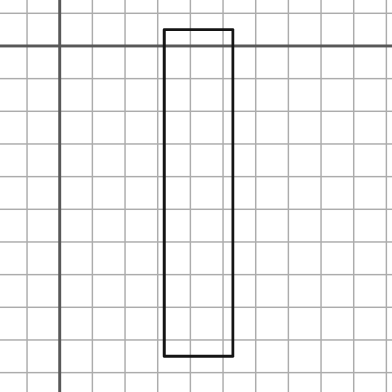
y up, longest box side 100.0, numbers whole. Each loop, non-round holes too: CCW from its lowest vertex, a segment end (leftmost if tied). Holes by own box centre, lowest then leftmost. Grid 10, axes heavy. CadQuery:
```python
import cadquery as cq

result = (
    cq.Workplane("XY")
    .moveTo(32.0, -95.0)
    .lineTo(53.0, -95.0)
    .lineTo(53.0, 5.0)
    .lineTo(32.0, 5.0)
    .close()
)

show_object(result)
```